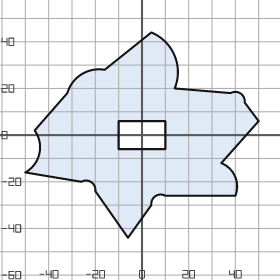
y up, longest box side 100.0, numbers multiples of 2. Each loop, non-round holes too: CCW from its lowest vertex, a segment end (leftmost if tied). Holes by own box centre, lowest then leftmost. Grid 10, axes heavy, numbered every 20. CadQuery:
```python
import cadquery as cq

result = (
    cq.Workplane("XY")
    .moveTo(-6.0, -44.0)
    .lineTo(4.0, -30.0)
    .threePointArc((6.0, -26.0), (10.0, -26.0))
    .lineTo(40.0, -26.0)
    .threePointArc((40.0, -18.0), (34.0, -12.0))
    .lineTo(50.0, 6.0)
    .lineTo(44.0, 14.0)
    .threePointArc((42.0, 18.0), (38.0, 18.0))
    .lineTo(14.0, 20.0)
    .threePointArc((14.0, 34.0), (4.0, 44.0))
    .lineTo(-16.0, 28.0)
    .threePointArc((-26.0, 26.0), (-32.0, 18.0))
    .lineTo(-46.0, 2.0)
    .threePointArc((-44.0, -8.0), (-50.0, -16.0))
    .lineTo(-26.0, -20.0)
    .threePointArc((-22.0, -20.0), (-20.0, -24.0))
    .close()
    .moveTo(-10.0, -6.0)
    .lineTo(10.0, -6.0)
    .lineTo(10.0, 6.0)
    .lineTo(-10.0, 6.0)
    .close()
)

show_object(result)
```